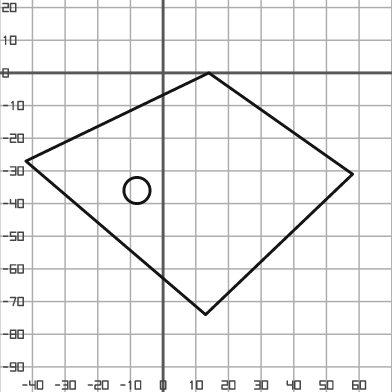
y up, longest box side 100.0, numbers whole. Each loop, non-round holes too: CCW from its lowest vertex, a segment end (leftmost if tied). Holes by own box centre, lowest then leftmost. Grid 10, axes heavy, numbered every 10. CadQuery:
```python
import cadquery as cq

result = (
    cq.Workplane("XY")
    .moveTo(13.0, -74.0)
    .lineTo(58.0, -31.0)
    .lineTo(14.0, 0.0)
    .lineTo(-42.0, -27.0)
    .close()
    .moveTo(-8.0, -36.0)
    .circle(4.0)
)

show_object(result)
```